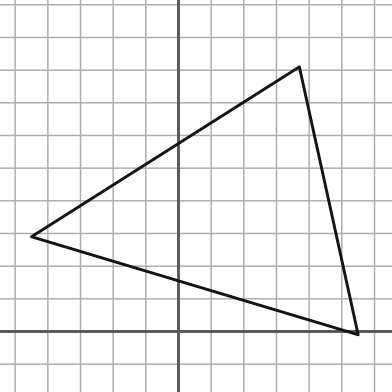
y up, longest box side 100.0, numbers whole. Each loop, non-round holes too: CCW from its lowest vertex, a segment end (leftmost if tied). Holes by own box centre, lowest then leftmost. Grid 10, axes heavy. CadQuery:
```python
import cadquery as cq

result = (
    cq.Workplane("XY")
    .moveTo(55.0, -1.0)
    .lineTo(37.0, 81.0)
    .lineTo(-45.0, 29.0)
    .close()
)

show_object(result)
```